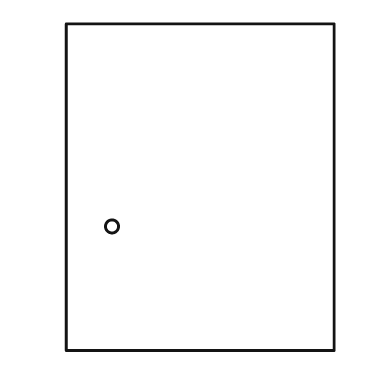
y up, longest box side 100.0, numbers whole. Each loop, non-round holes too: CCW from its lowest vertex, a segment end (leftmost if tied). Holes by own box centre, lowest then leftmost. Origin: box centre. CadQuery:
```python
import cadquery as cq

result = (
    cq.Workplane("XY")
    .moveTo(-41.0, -50.0)
    .lineTo(41.0, -50.0)
    .lineTo(41.0, 50.0)
    .lineTo(-41.0, 50.0)
    .close()
    .moveTo(-27.0, -12.0)
    .circle(2.0)
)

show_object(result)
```